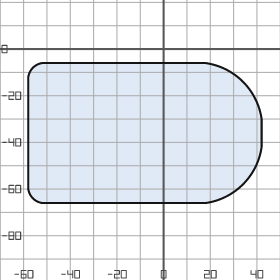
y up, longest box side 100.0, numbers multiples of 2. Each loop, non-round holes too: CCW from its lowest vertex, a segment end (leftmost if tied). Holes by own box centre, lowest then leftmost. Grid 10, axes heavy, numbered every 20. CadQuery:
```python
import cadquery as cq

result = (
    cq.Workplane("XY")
    .moveTo(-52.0, -66.0)
    .lineTo(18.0, -66.0)
    .threePointArc((34.0, -58.0), (42.0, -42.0))
    .lineTo(42.0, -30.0)
    .threePointArc((34.0, -14.0), (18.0, -6.0))
    .lineTo(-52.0, -6.0)
    .threePointArc((-56.0, -8.0), (-58.0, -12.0))
    .lineTo(-58.0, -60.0)
    .threePointArc((-56.0, -64.0), (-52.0, -66.0))
    .close()
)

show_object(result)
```